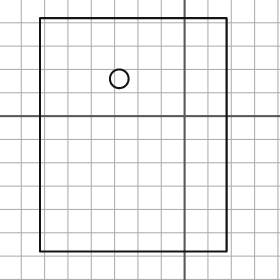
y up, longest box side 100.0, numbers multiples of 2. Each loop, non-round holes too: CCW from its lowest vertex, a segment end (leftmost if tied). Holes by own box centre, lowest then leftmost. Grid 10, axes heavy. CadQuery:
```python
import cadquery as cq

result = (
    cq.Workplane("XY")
    .moveTo(-62.0, -58.0)
    .lineTo(18.0, -58.0)
    .lineTo(18.0, 42.0)
    .lineTo(-62.0, 42.0)
    .close()
    .moveTo(-28.0, 16.0)
    .circle(4.0)
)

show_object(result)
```